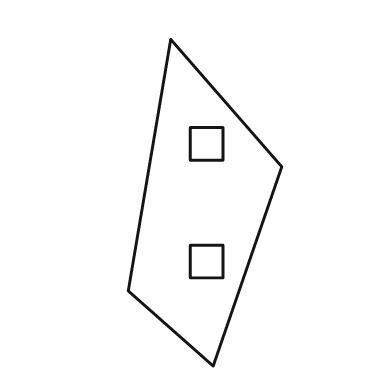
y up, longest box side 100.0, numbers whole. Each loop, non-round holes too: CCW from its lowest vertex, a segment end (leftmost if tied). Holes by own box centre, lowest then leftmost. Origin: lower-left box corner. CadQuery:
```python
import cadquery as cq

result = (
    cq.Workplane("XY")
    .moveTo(26.0, 0.0)
    .lineTo(47.0, 61.0)
    .lineTo(13.0, 100.0)
    .lineTo(0.0, 23.0)
    .close()
    .moveTo(19.0, 27.0)
    .lineTo(29.0, 27.0)
    .lineTo(29.0, 37.0)
    .lineTo(19.0, 37.0)
    .close()
    .moveTo(19.0, 63.0)
    .lineTo(29.0, 63.0)
    .lineTo(29.0, 73.0)
    .lineTo(19.0, 73.0)
    .close()
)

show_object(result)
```